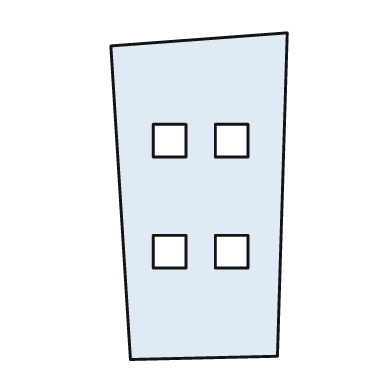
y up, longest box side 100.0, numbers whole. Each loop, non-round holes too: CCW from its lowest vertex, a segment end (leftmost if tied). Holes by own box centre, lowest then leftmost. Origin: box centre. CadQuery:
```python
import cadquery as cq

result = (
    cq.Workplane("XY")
    .moveTo(-21.0, -50.0)
    .lineTo(24.0, -49.0)
    .lineTo(27.0, 50.0)
    .lineTo(-27.0, 46.0)
    .close()
    .moveTo(-14.0, -22.0)
    .lineTo(-4.0, -22.0)
    .lineTo(-4.0, -12.0)
    .lineTo(-14.0, -12.0)
    .close()
    .moveTo(5.0, -22.0)
    .lineTo(15.0, -22.0)
    .lineTo(15.0, -12.0)
    .lineTo(5.0, -12.0)
    .close()
    .moveTo(-14.0, 12.0)
    .lineTo(-4.0, 12.0)
    .lineTo(-4.0, 22.0)
    .lineTo(-14.0, 22.0)
    .close()
    .moveTo(5.0, 12.0)
    .lineTo(15.0, 12.0)
    .lineTo(15.0, 22.0)
    .lineTo(5.0, 22.0)
    .close()
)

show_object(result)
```